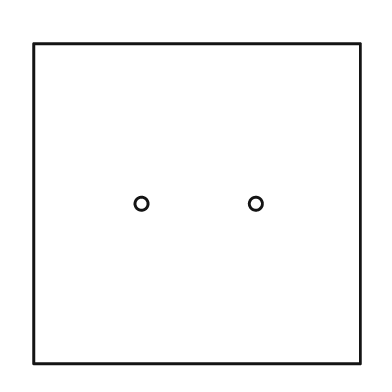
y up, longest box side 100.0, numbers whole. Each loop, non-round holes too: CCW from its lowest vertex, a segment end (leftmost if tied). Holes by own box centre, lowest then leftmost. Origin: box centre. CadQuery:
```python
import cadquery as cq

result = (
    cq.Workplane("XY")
    .moveTo(-50.0, -49.0)
    .lineTo(50.0, -49.0)
    .lineTo(50.0, 49.0)
    .lineTo(-50.0, 49.0)
    .close()
    .moveTo(-17.0, 0.0)
    .circle(2.0)
    .moveTo(18.0, 0.0)
    .circle(2.0)
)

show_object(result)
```